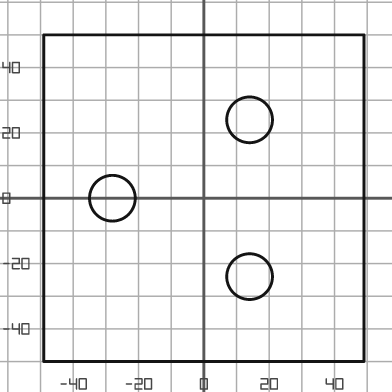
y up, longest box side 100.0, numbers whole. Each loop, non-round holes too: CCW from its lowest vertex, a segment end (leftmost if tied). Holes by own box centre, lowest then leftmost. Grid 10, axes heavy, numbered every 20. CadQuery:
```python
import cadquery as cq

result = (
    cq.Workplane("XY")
    .moveTo(-49.0, -50.0)
    .lineTo(49.0, -50.0)
    .lineTo(49.0, 50.0)
    .lineTo(-49.0, 50.0)
    .close()
    .moveTo(14.0, -24.0)
    .circle(7.0)
    .moveTo(-28.0, 0.0)
    .circle(7.0)
    .moveTo(14.0, 24.0)
    .circle(7.0)
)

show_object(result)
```